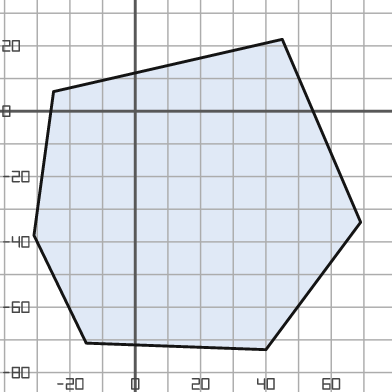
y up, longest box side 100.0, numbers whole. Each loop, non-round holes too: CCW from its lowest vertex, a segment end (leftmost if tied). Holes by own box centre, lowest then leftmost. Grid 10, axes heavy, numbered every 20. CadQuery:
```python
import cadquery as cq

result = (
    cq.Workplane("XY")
    .moveTo(40.0, -73.0)
    .lineTo(69.0, -34.0)
    .lineTo(45.0, 22.0)
    .lineTo(-25.0, 6.0)
    .lineTo(-31.0, -38.0)
    .lineTo(-15.0, -71.0)
    .close()
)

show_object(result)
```